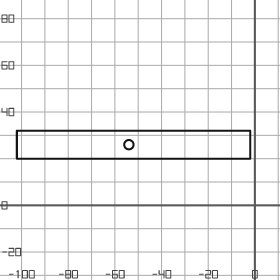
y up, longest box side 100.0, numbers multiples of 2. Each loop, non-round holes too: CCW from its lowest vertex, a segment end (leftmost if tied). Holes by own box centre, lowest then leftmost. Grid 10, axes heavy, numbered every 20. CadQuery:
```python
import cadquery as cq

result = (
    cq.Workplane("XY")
    .moveTo(-102.0, 20.0)
    .lineTo(-2.0, 20.0)
    .lineTo(-2.0, 32.0)
    .lineTo(-102.0, 32.0)
    .close()
    .moveTo(-54.0, 26.0)
    .circle(2.0)
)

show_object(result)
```